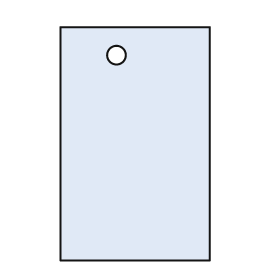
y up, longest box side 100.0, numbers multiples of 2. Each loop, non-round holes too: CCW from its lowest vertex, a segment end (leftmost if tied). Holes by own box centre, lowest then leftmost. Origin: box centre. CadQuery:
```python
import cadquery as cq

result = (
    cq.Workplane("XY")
    .moveTo(-32.0, -50.0)
    .lineTo(32.0, -50.0)
    .lineTo(32.0, 50.0)
    .lineTo(-32.0, 50.0)
    .close()
    .moveTo(-8.0, 38.0)
    .circle(4.0)
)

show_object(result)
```